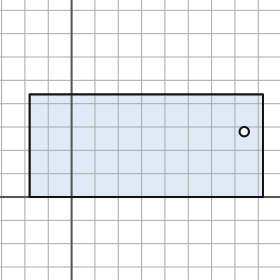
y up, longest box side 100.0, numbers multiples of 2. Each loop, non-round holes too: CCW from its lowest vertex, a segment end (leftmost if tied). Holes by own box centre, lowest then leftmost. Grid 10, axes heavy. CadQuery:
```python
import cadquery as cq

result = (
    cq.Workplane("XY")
    .moveTo(-18.0, 0.0)
    .lineTo(82.0, 0.0)
    .lineTo(82.0, 44.0)
    .lineTo(-18.0, 44.0)
    .close()
    .moveTo(74.0, 28.0)
    .circle(2.0)
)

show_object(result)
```